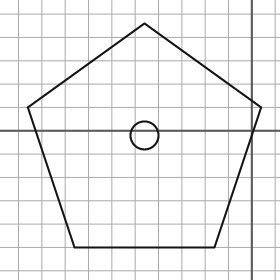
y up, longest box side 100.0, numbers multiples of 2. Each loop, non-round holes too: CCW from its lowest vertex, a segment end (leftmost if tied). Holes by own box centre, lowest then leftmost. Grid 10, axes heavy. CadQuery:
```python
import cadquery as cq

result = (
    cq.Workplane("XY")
    .moveTo(-76.0, -50.0)
    .lineTo(-16.0, -50.0)
    .lineTo(4.0, 10.0)
    .lineTo(-46.0, 46.0)
    .lineTo(-96.0, 10.0)
    .close()
    .moveTo(-46.0, -2.0)
    .circle(6.0)
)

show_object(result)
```